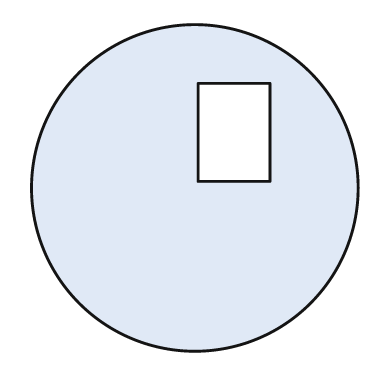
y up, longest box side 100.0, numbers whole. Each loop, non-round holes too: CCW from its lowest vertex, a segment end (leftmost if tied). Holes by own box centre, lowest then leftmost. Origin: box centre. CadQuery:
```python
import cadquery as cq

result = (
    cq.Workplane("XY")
    .moveTo(0.0, 0.0)
    .circle(50.0)
    .moveTo(1.0, 2.0)
    .lineTo(23.0, 2.0)
    .lineTo(23.0, 32.0)
    .lineTo(1.0, 32.0)
    .close()
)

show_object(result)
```